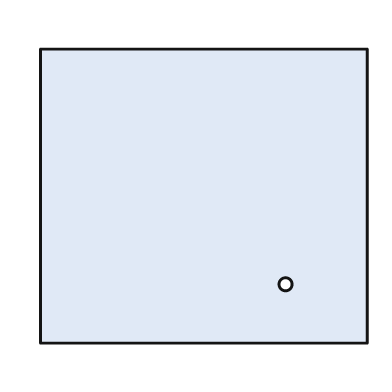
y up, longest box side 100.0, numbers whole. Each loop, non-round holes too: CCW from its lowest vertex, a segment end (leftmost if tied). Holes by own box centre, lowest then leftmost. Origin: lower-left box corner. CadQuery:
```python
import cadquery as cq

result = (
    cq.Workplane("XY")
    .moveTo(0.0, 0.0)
    .lineTo(100.0, 0.0)
    .lineTo(100.0, 90.0)
    .lineTo(0.0, 90.0)
    .close()
    .moveTo(75.0, 18.0)
    .circle(2.0)
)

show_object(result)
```